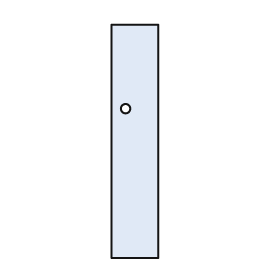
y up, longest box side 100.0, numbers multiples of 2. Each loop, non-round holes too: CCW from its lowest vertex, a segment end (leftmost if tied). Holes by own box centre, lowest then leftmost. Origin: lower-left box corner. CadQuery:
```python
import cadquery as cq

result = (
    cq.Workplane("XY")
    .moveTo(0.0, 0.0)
    .lineTo(20.0, 0.0)
    .lineTo(20.0, 100.0)
    .lineTo(0.0, 100.0)
    .close()
    .moveTo(6.0, 64.0)
    .circle(2.0)
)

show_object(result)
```